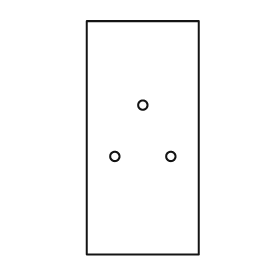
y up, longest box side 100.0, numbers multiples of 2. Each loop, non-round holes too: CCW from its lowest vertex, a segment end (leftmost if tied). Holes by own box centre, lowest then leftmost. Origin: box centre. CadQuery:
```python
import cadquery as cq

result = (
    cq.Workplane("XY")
    .moveTo(-24.0, -50.0)
    .lineTo(24.0, -50.0)
    .lineTo(24.0, 50.0)
    .lineTo(-24.0, 50.0)
    .close()
    .moveTo(-12.0, -8.0)
    .circle(2.0)
    .moveTo(12.0, -8.0)
    .circle(2.0)
    .moveTo(0.0, 14.0)
    .circle(2.0)
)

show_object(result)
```